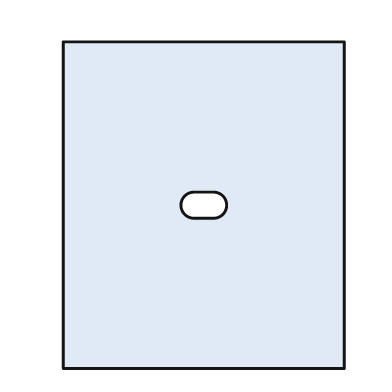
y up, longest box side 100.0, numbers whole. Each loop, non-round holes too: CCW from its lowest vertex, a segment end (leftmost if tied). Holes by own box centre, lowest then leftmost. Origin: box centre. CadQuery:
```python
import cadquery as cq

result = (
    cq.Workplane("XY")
    .moveTo(-43.0, -50.0)
    .lineTo(43.0, -50.0)
    .lineTo(43.0, 50.0)
    .lineTo(-43.0, 50.0)
    .close()
    .moveTo(-3.0, -4.0)
    .lineTo(3.0, -4.0)
    .threePointArc((7.0, 0.0), (3.0, 4.0))
    .lineTo(-3.0, 4.0)
    .threePointArc((-7.0, 0.0), (-3.0, -4.0))
    .close()
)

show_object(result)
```